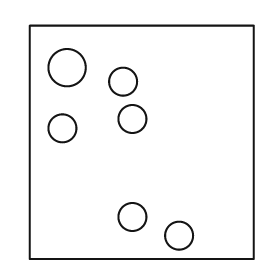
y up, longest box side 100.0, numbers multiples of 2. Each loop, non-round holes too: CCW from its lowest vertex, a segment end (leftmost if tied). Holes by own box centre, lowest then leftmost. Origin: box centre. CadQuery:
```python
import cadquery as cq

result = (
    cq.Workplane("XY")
    .moveTo(-48.0, -50.0)
    .lineTo(48.0, -50.0)
    .lineTo(48.0, 50.0)
    .lineTo(-48.0, 50.0)
    .close()
    .moveTo(16.0, -40.0)
    .circle(6.0)
    .moveTo(-4.0, -32.0)
    .circle(6.0)
    .moveTo(-34.0, 6.0)
    .circle(6.0)
    .moveTo(-4.0, 10.0)
    .circle(6.0)
    .moveTo(-8.0, 26.0)
    .circle(6.0)
    .moveTo(-32.0, 32.0)
    .circle(8.0)
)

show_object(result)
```